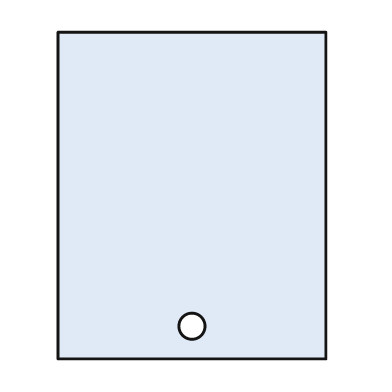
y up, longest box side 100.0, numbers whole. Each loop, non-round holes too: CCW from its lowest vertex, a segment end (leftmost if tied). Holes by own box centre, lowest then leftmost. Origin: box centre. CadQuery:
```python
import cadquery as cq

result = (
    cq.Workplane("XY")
    .moveTo(-41.0, -50.0)
    .lineTo(41.0, -50.0)
    .lineTo(41.0, 50.0)
    .lineTo(-41.0, 50.0)
    .close()
    .moveTo(0.0, -40.0)
    .circle(4.0)
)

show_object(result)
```